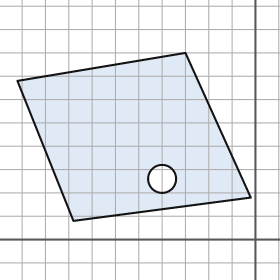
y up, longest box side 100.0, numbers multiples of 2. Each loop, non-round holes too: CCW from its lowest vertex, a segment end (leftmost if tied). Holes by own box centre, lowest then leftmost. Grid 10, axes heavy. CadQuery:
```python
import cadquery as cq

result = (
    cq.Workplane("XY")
    .moveTo(-78.0, 8.0)
    .lineTo(-2.0, 18.0)
    .lineTo(-30.0, 80.0)
    .lineTo(-102.0, 68.0)
    .close()
    .moveTo(-40.0, 26.0)
    .circle(6.0)
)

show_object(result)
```